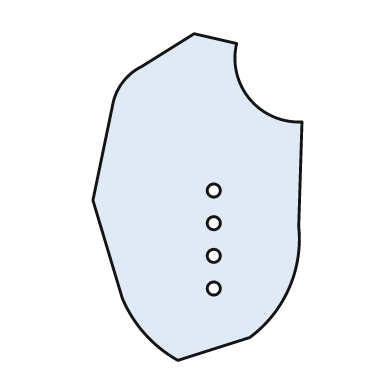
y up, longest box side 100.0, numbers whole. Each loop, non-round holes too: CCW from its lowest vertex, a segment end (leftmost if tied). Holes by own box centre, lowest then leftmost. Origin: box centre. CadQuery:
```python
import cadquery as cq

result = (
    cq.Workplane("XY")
    .moveTo(-6.0, -50.0)
    .lineTo(16.0, -43.0)
    .threePointArc((28.0, -28.0), (31.0, -9.0))
    .lineTo(32.0, 23.0)
    .threePointArc((16.0, 30.0), (12.0, 47.0))
    .lineTo(-1.0, 50.0)
    .lineTo(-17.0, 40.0)
    .threePointArc((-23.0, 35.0), (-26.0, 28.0))
    .lineTo(-32.0, -1.0)
    .lineTo(-23.0, -31.0)
    .threePointArc((-16.0, -42.0), (-6.0, -50.0))
    .close()
    .moveTo(5.0, -28.0)
    .circle(2.0)
    .moveTo(5.0, -18.0)
    .circle(2.0)
    .moveTo(5.0, -8.0)
    .circle(2.0)
    .moveTo(5.0, 2.0)
    .circle(2.0)
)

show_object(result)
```